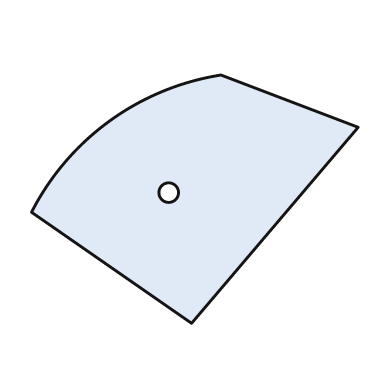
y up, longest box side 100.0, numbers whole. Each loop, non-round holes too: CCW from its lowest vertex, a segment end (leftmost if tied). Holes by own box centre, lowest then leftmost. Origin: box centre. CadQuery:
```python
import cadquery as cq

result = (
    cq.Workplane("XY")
    .moveTo(-1.0, -38.0)
    .lineTo(50.0, 22.0)
    .lineTo(8.0, 38.0)
    .threePointArc((-26.0, 24.0), (-50.0, -4.0))
    .close()
    .moveTo(-8.0, 2.0)
    .circle(3.0)
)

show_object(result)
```